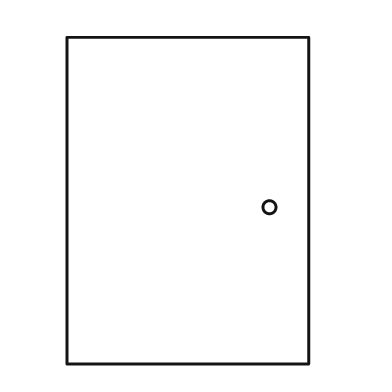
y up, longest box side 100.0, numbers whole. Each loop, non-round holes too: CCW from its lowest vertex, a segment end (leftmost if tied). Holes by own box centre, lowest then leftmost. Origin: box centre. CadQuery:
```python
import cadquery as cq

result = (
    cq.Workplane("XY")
    .moveTo(-37.0, -50.0)
    .lineTo(37.0, -50.0)
    .lineTo(37.0, 50.0)
    .lineTo(-37.0, 50.0)
    .close()
    .moveTo(25.0, -2.0)
    .circle(2.0)
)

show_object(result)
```